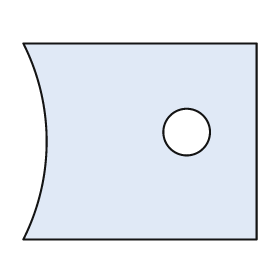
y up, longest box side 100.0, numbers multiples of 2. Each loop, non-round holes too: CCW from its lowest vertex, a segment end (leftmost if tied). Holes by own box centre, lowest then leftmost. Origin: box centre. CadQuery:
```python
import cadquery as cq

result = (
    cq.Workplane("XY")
    .moveTo(-50.0, -42.0)
    .lineTo(50.0, -42.0)
    .lineTo(50.0, 42.0)
    .lineTo(-50.0, 42.0)
    .threePointArc((-40.0, 0.0), (-50.0, -42.0))
    .close()
    .moveTo(20.0, 4.0)
    .circle(10.0)
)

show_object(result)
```